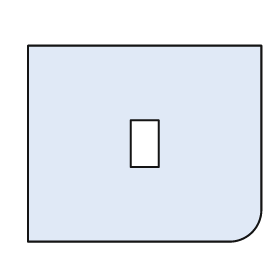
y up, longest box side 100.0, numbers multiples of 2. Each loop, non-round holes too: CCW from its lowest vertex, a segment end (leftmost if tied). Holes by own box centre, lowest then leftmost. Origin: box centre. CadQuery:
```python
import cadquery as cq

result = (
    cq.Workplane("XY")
    .moveTo(-50.0, -42.0)
    .lineTo(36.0, -42.0)
    .threePointArc((46.0, -38.0), (50.0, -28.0))
    .lineTo(50.0, 42.0)
    .lineTo(-50.0, 42.0)
    .close()
    .moveTo(-6.0, -10.0)
    .lineTo(6.0, -10.0)
    .lineTo(6.0, 10.0)
    .lineTo(-6.0, 10.0)
    .close()
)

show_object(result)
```